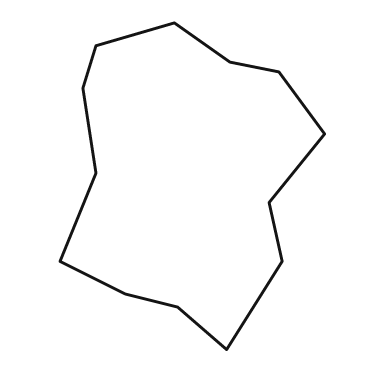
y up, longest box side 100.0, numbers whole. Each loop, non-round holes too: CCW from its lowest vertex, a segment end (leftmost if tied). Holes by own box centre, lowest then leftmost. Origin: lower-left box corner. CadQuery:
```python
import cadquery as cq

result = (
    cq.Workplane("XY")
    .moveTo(51.0, 0.0)
    .lineTo(68.0, 27.0)
    .lineTo(64.0, 45.0)
    .lineTo(81.0, 66.0)
    .lineTo(67.0, 85.0)
    .lineTo(52.0, 88.0)
    .lineTo(35.0, 100.0)
    .lineTo(11.0, 93.0)
    .lineTo(7.0, 80.0)
    .lineTo(11.0, 54.0)
    .lineTo(0.0, 27.0)
    .lineTo(20.0, 17.0)
    .lineTo(36.0, 13.0)
    .close()
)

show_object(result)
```